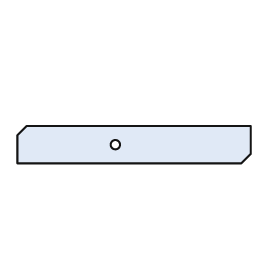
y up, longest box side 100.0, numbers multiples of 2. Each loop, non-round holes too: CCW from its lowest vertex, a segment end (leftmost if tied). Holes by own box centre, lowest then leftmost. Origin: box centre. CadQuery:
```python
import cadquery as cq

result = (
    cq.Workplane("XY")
    .moveTo(-50.0, -8.0)
    .lineTo(46.0, -8.0)
    .lineTo(50.0, -4.0)
    .lineTo(50.0, 8.0)
    .lineTo(-46.0, 8.0)
    .lineTo(-50.0, 4.0)
    .close()
    .moveTo(-8.0, 0.0)
    .circle(2.0)
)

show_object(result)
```